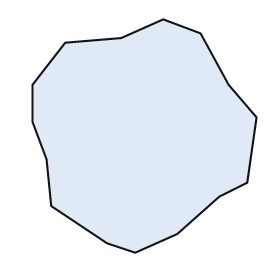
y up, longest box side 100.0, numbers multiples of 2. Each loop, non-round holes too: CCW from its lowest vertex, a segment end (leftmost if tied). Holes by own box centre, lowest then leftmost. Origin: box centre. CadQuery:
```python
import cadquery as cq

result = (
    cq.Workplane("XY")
    .moveTo(-4.0, -50.0)
    .lineTo(14.0, -42.0)
    .lineTo(32.0, -26.0)
    .lineTo(44.0, -20.0)
    .lineTo(48.0, 8.0)
    .lineTo(36.0, 22.0)
    .lineTo(24.0, 44.0)
    .lineTo(8.0, 50.0)
    .lineTo(-10.0, 42.0)
    .lineTo(-34.0, 40.0)
    .lineTo(-48.0, 22.0)
    .lineTo(-48.0, 6.0)
    .lineTo(-42.0, -10.0)
    .lineTo(-40.0, -30.0)
    .lineTo(-16.0, -46.0)
    .close()
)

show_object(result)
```